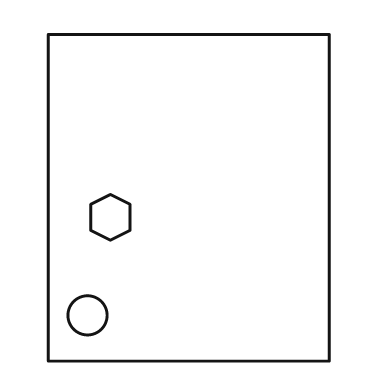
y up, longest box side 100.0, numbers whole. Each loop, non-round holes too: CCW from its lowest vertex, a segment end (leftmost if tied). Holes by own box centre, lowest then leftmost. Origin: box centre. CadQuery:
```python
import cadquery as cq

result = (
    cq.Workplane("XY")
    .moveTo(-43.0, -50.0)
    .lineTo(43.0, -50.0)
    .lineTo(43.0, 50.0)
    .lineTo(-43.0, 50.0)
    .close()
    .moveTo(-31.0, -36.0)
    .circle(6.0)
    .moveTo(-24.0, -13.0)
    .lineTo(-18.0, -10.0)
    .lineTo(-18.0, -2.0)
    .lineTo(-24.0, 1.0)
    .lineTo(-30.0, -2.0)
    .lineTo(-30.0, -10.0)
    .close()
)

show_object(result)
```